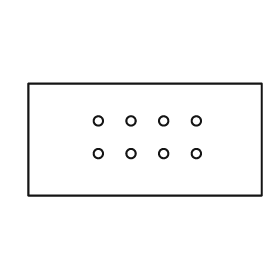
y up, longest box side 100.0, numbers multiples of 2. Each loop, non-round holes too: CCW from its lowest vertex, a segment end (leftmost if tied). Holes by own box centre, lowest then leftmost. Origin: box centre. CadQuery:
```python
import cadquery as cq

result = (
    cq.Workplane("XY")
    .moveTo(-50.0, -24.0)
    .lineTo(50.0, -24.0)
    .lineTo(50.0, 24.0)
    .lineTo(-50.0, 24.0)
    .close()
    .moveTo(-20.0, -6.0)
    .circle(2.0)
    .moveTo(-6.0, -6.0)
    .circle(2.0)
    .moveTo(8.0, -6.0)
    .circle(2.0)
    .moveTo(22.0, -6.0)
    .circle(2.0)
    .moveTo(-20.0, 8.0)
    .circle(2.0)
    .moveTo(-6.0, 8.0)
    .circle(2.0)
    .moveTo(8.0, 8.0)
    .circle(2.0)
    .moveTo(22.0, 8.0)
    .circle(2.0)
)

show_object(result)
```